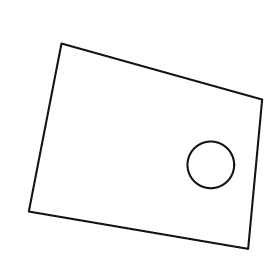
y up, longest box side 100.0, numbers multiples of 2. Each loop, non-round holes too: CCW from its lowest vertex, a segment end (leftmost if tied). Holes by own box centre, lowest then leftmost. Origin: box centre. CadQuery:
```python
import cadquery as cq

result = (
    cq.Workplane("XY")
    .moveTo(44.0, -44.0)
    .lineTo(50.0, 20.0)
    .lineTo(-36.0, 44.0)
    .lineTo(-50.0, -28.0)
    .close()
    .moveTo(28.0, -8.0)
    .circle(10.0)
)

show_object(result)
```